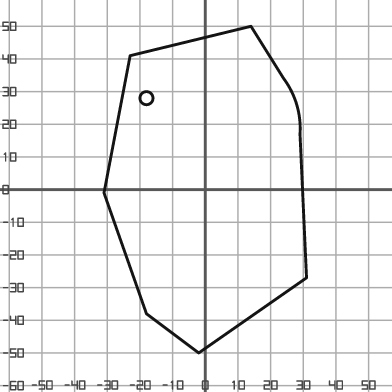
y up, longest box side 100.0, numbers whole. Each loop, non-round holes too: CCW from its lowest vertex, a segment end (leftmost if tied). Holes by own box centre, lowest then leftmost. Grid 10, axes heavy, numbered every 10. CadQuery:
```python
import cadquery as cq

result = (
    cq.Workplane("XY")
    .moveTo(-2.0, -50.0)
    .lineTo(31.0, -27.0)
    .lineTo(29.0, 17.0)
    .threePointArc((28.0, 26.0), (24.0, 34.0))
    .lineTo(14.0, 50.0)
    .lineTo(-23.0, 41.0)
    .lineTo(-31.0, -1.0)
    .lineTo(-18.0, -38.0)
    .close()
    .moveTo(-18.0, 28.0)
    .circle(2.0)
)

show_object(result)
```